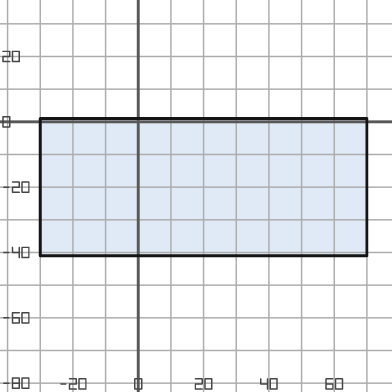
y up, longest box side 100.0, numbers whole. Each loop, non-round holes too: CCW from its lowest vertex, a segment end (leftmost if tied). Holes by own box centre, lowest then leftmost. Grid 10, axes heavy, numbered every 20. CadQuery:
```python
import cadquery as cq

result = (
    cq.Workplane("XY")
    .moveTo(-30.0, -41.0)
    .lineTo(70.0, -41.0)
    .lineTo(70.0, 1.0)
    .lineTo(-30.0, 1.0)
    .close()
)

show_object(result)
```